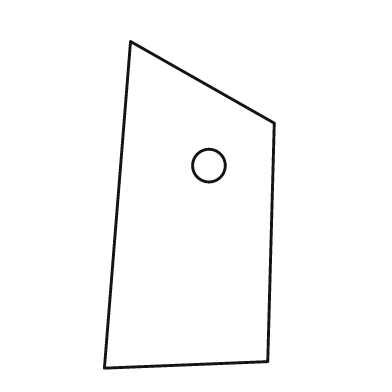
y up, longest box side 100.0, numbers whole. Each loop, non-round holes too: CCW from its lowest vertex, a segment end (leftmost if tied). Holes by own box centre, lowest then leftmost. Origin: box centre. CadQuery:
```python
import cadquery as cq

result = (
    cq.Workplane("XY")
    .moveTo(-26.0, -50.0)
    .lineTo(24.0, -48.0)
    .lineTo(26.0, 25.0)
    .lineTo(-18.0, 50.0)
    .close()
    .moveTo(6.0, 12.0)
    .circle(5.0)
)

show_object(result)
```